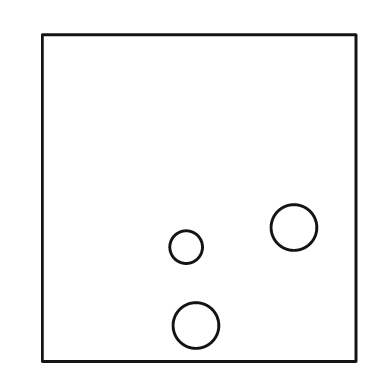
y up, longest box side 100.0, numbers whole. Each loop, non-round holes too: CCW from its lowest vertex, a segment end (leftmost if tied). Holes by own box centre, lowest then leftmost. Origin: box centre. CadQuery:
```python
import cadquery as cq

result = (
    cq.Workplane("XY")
    .moveTo(-48.0, -50.0)
    .lineTo(48.0, -50.0)
    .lineTo(48.0, 50.0)
    .lineTo(-48.0, 50.0)
    .close()
    .moveTo(-1.0, -39.0)
    .circle(7.0)
    .moveTo(-4.0, -15.0)
    .circle(5.0)
    .moveTo(29.0, -9.0)
    .circle(7.0)
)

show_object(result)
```